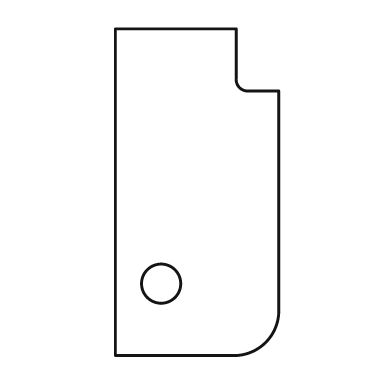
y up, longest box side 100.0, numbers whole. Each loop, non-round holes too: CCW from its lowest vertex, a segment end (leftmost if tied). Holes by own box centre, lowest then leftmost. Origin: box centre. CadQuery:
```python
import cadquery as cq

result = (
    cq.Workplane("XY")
    .moveTo(-25.0, -50.0)
    .lineTo(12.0, -50.0)
    .threePointArc((21.0, -46.0), (25.0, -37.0))
    .lineTo(25.0, 31.0)
    .lineTo(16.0, 31.0)
    .threePointArc((13.0, 32.0), (12.0, 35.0))
    .lineTo(12.0, 50.0)
    .lineTo(-25.0, 50.0)
    .close()
    .moveTo(-11.0, -28.0)
    .circle(6.0)
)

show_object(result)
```